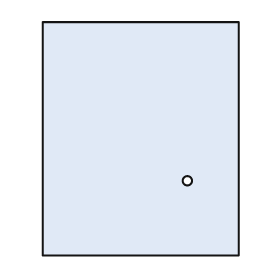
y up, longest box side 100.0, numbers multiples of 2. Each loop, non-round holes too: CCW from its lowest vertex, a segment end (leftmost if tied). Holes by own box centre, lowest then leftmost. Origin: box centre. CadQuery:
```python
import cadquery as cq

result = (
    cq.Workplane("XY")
    .moveTo(-42.0, -50.0)
    .lineTo(42.0, -50.0)
    .lineTo(42.0, 50.0)
    .lineTo(-42.0, 50.0)
    .close()
    .moveTo(20.0, -18.0)
    .circle(2.0)
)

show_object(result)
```